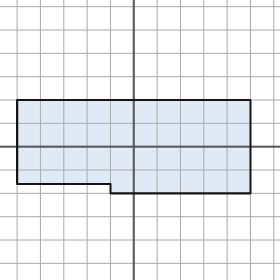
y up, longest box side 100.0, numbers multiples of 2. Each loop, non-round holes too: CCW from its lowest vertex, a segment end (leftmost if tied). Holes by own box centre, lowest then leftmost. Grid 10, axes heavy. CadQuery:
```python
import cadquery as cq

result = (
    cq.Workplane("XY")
    .moveTo(-10.0, -20.0)
    .lineTo(50.0, -20.0)
    .lineTo(50.0, 20.0)
    .lineTo(-50.0, 20.0)
    .lineTo(-50.0, -16.0)
    .lineTo(-10.0, -16.0)
    .close()
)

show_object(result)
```